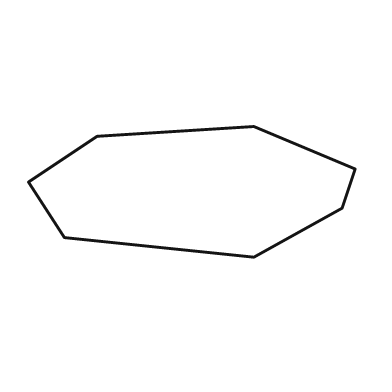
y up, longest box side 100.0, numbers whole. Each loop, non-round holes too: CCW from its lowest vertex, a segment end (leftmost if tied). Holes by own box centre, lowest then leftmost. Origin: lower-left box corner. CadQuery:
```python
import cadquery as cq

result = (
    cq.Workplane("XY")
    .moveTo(69.0, 0.0)
    .lineTo(96.0, 15.0)
    .lineTo(100.0, 27.0)
    .lineTo(69.0, 40.0)
    .lineTo(21.0, 37.0)
    .lineTo(0.0, 23.0)
    .lineTo(11.0, 6.0)
    .close()
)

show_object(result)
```